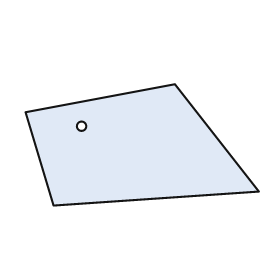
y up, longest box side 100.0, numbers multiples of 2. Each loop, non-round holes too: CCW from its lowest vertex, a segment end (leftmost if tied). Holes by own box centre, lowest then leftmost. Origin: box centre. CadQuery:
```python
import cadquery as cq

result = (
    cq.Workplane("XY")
    .moveTo(-38.0, -26.0)
    .lineTo(50.0, -20.0)
    .lineTo(14.0, 26.0)
    .lineTo(-50.0, 14.0)
    .close()
    .moveTo(-26.0, 8.0)
    .circle(2.0)
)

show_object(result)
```